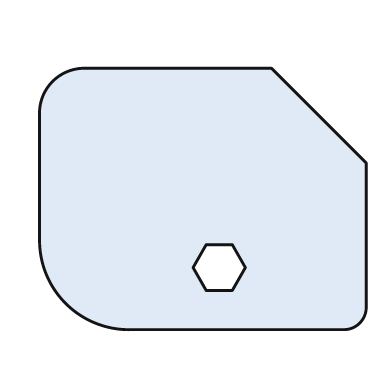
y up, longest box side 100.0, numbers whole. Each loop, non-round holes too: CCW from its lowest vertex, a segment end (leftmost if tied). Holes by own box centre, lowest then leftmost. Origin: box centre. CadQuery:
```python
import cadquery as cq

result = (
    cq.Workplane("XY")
    .moveTo(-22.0, -40.0)
    .lineTo(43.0, -40.0)
    .threePointArc((48.0, -38.0), (50.0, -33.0))
    .lineTo(50.0, 11.0)
    .lineTo(21.0, 40.0)
    .lineTo(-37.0, 40.0)
    .threePointArc((-46.0, 36.0), (-50.0, 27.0))
    .lineTo(-50.0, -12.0)
    .threePointArc((-42.0, -32.0), (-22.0, -40.0))
    .close()
    .moveTo(1.0, -28.0)
    .lineTo(9.0, -28.0)
    .lineTo(13.0, -21.0)
    .lineTo(9.0, -14.0)
    .lineTo(1.0, -14.0)
    .lineTo(-3.0, -21.0)
    .close()
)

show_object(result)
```